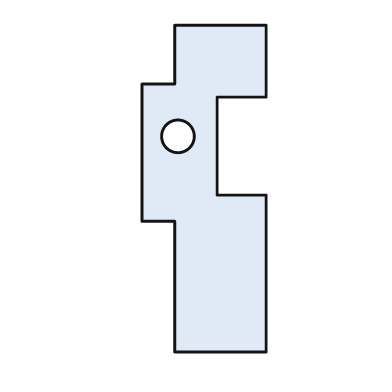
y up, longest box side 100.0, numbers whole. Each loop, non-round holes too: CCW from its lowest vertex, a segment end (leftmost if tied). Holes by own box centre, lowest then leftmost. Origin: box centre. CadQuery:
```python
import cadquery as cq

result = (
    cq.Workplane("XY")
    .moveTo(-9.0, -50.0)
    .lineTo(19.0, -50.0)
    .lineTo(19.0, -2.0)
    .lineTo(4.0, -2.0)
    .lineTo(4.0, 28.0)
    .lineTo(19.0, 28.0)
    .lineTo(19.0, 50.0)
    .lineTo(-9.0, 50.0)
    .lineTo(-9.0, 32.0)
    .lineTo(-19.0, 32.0)
    .lineTo(-19.0, -10.0)
    .lineTo(-9.0, -10.0)
    .close()
    .moveTo(-8.0, 16.0)
    .circle(5.0)
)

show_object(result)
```